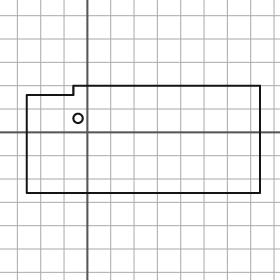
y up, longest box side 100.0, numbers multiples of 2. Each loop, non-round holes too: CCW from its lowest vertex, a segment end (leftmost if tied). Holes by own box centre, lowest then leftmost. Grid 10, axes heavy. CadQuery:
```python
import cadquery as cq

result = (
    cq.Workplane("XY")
    .moveTo(-26.0, -26.0)
    .lineTo(74.0, -26.0)
    .lineTo(74.0, 20.0)
    .lineTo(-6.0, 20.0)
    .lineTo(-6.0, 16.0)
    .lineTo(-26.0, 16.0)
    .close()
    .moveTo(-4.0, 6.0)
    .circle(2.0)
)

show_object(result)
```